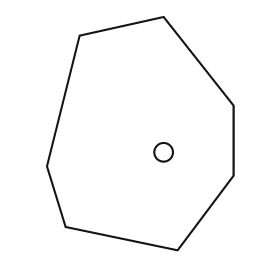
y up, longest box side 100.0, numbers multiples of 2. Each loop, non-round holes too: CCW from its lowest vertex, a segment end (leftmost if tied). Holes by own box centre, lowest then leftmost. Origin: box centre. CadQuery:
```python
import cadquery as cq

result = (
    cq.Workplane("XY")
    .moveTo(16.0, -50.0)
    .lineTo(40.0, -18.0)
    .lineTo(40.0, 12.0)
    .lineTo(10.0, 50.0)
    .lineTo(-26.0, 42.0)
    .lineTo(-40.0, -14.0)
    .lineTo(-32.0, -40.0)
    .close()
    .moveTo(10.0, -8.0)
    .circle(4.0)
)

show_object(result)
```